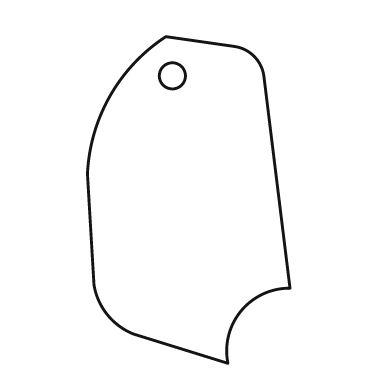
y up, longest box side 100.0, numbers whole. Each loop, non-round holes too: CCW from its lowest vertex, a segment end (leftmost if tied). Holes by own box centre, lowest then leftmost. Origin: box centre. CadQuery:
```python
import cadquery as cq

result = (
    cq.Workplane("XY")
    .moveTo(12.0, -50.0)
    .threePointArc((16.0, -34.0), (31.0, -27.0))
    .lineTo(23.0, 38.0)
    .threePointArc((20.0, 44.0), (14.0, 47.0))
    .lineTo(-7.0, 50.0)
    .threePointArc((-24.0, 32.0), (-31.0, 8.0))
    .lineTo(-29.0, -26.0)
    .threePointArc((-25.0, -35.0), (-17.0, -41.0))
    .close()
    .moveTo(-5.0, 38.0)
    .circle(4.0)
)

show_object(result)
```